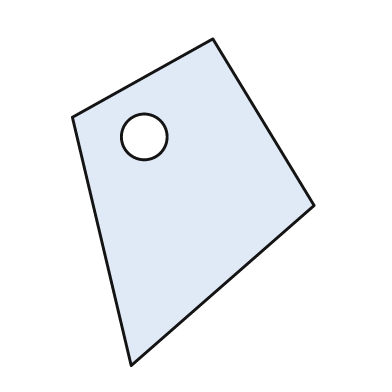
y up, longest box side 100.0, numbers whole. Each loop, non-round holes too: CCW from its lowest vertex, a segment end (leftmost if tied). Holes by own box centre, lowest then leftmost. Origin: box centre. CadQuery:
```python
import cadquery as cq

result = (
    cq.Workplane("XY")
    .moveTo(-19.0, -50.0)
    .lineTo(37.0, -1.0)
    .lineTo(6.0, 50.0)
    .lineTo(-37.0, 26.0)
    .close()
    .moveTo(-15.0, 20.0)
    .circle(7.0)
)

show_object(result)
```